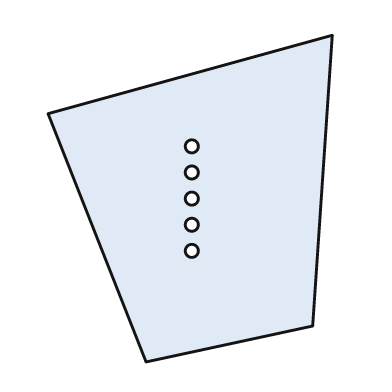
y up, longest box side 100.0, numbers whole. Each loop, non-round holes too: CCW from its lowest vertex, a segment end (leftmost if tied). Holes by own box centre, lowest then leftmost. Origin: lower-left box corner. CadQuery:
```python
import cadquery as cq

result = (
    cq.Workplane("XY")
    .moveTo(30.0, 0.0)
    .lineTo(81.0, 11.0)
    .lineTo(87.0, 100.0)
    .lineTo(0.0, 76.0)
    .close()
    .moveTo(44.0, 34.0)
    .circle(2.0)
    .moveTo(44.0, 42.0)
    .circle(2.0)
    .moveTo(44.0, 50.0)
    .circle(2.0)
    .moveTo(44.0, 58.0)
    .circle(2.0)
    .moveTo(44.0, 66.0)
    .circle(2.0)
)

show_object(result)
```